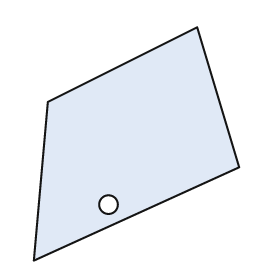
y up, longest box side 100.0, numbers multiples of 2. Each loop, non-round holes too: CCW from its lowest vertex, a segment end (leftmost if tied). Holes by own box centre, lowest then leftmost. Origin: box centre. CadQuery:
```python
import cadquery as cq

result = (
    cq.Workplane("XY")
    .moveTo(-44.0, -50.0)
    .lineTo(44.0, -10.0)
    .lineTo(26.0, 50.0)
    .lineTo(-38.0, 18.0)
    .close()
    .moveTo(-12.0, -26.0)
    .circle(4.0)
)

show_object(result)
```